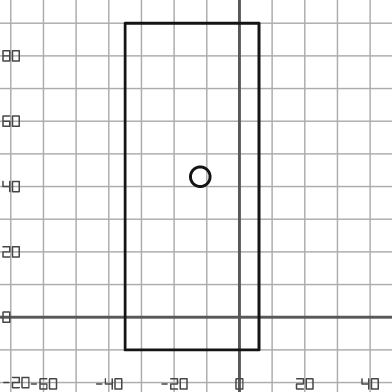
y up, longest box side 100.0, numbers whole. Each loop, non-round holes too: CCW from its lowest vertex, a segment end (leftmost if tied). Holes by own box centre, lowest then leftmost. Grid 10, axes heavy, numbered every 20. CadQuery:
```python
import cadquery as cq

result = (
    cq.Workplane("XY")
    .moveTo(-35.0, -10.0)
    .lineTo(6.0, -10.0)
    .lineTo(6.0, 90.0)
    .lineTo(-35.0, 90.0)
    .close()
    .moveTo(-12.0, 43.0)
    .circle(3.0)
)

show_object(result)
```